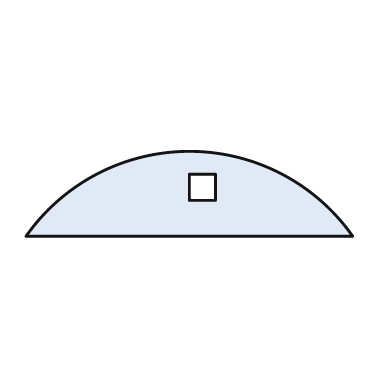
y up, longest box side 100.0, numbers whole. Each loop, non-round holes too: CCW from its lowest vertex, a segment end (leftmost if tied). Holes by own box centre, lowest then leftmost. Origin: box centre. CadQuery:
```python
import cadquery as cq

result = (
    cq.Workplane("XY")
    .moveTo(-50.0, -13.0)
    .lineTo(50.0, -13.0)
    .threePointArc((0.0, 13.0), (-50.0, -13.0))
    .close()
    .moveTo(0.0, -2.0)
    .lineTo(8.0, -2.0)
    .lineTo(8.0, 6.0)
    .lineTo(0.0, 6.0)
    .close()
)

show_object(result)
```